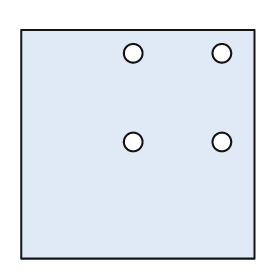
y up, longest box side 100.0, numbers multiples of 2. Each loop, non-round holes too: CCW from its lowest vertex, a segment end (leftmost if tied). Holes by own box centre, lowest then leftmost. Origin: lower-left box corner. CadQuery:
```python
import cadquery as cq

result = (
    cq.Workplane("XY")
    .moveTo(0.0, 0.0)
    .lineTo(100.0, 0.0)
    .lineTo(100.0, 98.0)
    .lineTo(0.0, 98.0)
    .close()
    .moveTo(48.0, 50.0)
    .circle(4.0)
    .moveTo(86.0, 50.0)
    .circle(4.0)
    .moveTo(48.0, 88.0)
    .circle(4.0)
    .moveTo(86.0, 88.0)
    .circle(4.0)
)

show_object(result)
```